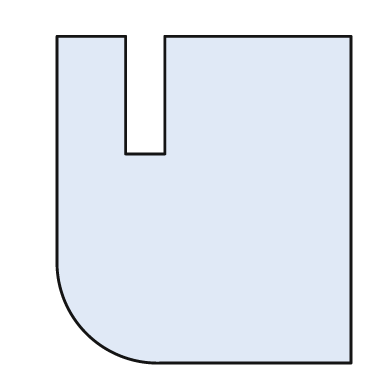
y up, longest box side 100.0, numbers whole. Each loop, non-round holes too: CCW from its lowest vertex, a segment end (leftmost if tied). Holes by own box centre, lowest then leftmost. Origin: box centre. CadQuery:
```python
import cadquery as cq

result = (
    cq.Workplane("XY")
    .moveTo(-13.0, -50.0)
    .lineTo(45.0, -50.0)
    .lineTo(45.0, 50.0)
    .lineTo(-12.0, 50.0)
    .lineTo(-12.0, 14.0)
    .lineTo(-24.0, 14.0)
    .lineTo(-24.0, 50.0)
    .lineTo(-45.0, 50.0)
    .lineTo(-45.0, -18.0)
    .threePointArc((-36.0, -41.0), (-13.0, -50.0))
    .close()
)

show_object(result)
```